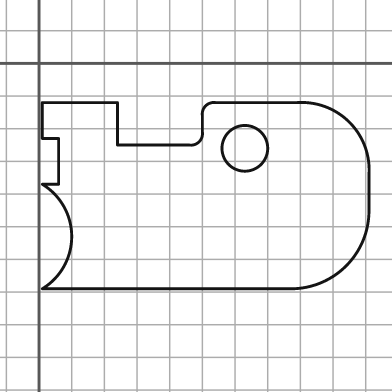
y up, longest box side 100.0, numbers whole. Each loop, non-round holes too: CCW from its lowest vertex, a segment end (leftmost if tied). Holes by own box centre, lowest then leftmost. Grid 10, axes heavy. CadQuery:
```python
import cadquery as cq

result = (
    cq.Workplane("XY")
    .moveTo(1.0, -69.0)
    .lineTo(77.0, -69.0)
    .threePointArc((94.0, -62.0), (101.0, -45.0))
    .lineTo(101.0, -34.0)
    .threePointArc((95.0, -18.0), (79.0, -12.0))
    .lineTo(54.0, -12.0)
    .threePointArc((51.0, -13.0), (50.0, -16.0))
    .lineTo(50.0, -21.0)
    .threePointArc((49.0, -24.0), (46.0, -25.0))
    .lineTo(24.0, -25.0)
    .lineTo(24.0, -12.0)
    .lineTo(1.0, -12.0)
    .lineTo(1.0, -23.0)
    .lineTo(6.0, -23.0)
    .lineTo(6.0, -37.0)
    .lineTo(1.0, -37.0)
    .threePointArc((10.0, -53.0), (1.0, -69.0))
    .close()
    .moveTo(63.0, -26.0)
    .circle(7.0)
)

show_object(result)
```